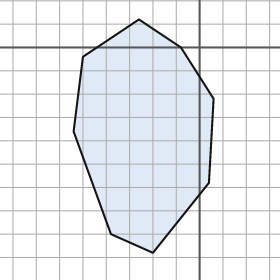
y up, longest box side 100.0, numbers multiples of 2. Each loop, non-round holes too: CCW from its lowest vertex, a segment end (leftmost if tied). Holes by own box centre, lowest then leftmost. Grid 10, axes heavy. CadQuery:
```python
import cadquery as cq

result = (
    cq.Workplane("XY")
    .moveTo(-20.0, -88.0)
    .lineTo(4.0, -58.0)
    .lineTo(6.0, -22.0)
    .lineTo(-8.0, 0.0)
    .lineTo(-26.0, 12.0)
    .lineTo(-50.0, -4.0)
    .lineTo(-54.0, -36.0)
    .lineTo(-38.0, -80.0)
    .close()
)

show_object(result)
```